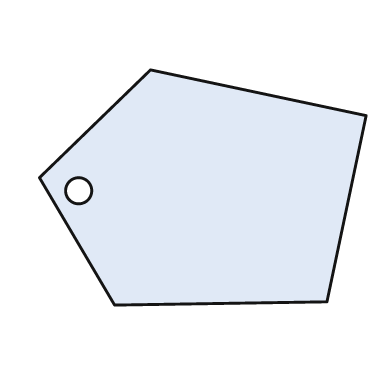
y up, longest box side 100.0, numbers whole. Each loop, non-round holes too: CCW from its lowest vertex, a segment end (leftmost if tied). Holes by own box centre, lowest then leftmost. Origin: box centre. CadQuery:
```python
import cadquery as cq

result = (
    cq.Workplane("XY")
    .moveTo(-27.0, -36.0)
    .lineTo(38.0, -35.0)
    .lineTo(50.0, 22.0)
    .lineTo(-16.0, 36.0)
    .lineTo(-50.0, 3.0)
    .close()
    .moveTo(-38.0, -1.0)
    .circle(4.0)
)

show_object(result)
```